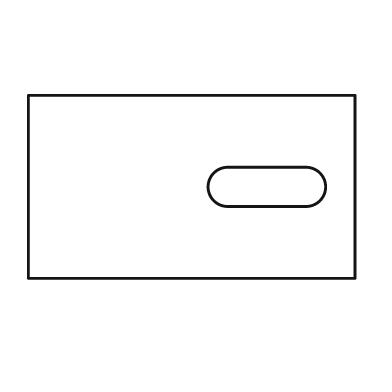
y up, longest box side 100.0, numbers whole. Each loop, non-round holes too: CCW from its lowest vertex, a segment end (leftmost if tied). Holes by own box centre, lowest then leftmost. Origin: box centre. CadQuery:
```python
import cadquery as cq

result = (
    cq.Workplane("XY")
    .moveTo(-50.0, -28.0)
    .lineTo(50.0, -28.0)
    .lineTo(50.0, 28.0)
    .lineTo(-50.0, 28.0)
    .close()
    .moveTo(11.0, -6.0)
    .lineTo(35.0, -6.0)
    .threePointArc((41.0, 0.0), (35.0, 6.0))
    .lineTo(11.0, 6.0)
    .threePointArc((5.0, 0.0), (11.0, -6.0))
    .close()
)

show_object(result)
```